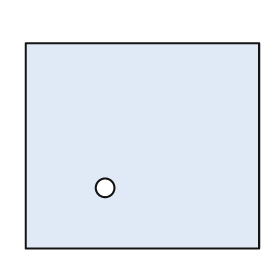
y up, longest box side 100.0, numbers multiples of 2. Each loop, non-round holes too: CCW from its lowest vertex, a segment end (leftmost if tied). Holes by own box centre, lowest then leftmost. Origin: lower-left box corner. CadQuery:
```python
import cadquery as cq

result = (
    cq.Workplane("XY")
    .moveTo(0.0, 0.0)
    .lineTo(100.0, 0.0)
    .lineTo(100.0, 88.0)
    .lineTo(0.0, 88.0)
    .close()
    .moveTo(34.0, 26.0)
    .circle(4.0)
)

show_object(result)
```